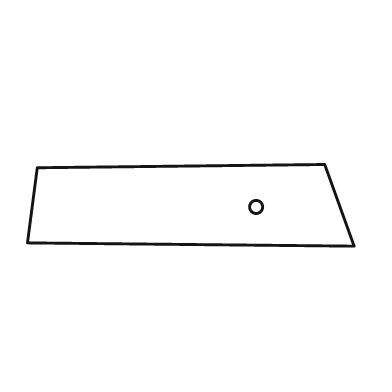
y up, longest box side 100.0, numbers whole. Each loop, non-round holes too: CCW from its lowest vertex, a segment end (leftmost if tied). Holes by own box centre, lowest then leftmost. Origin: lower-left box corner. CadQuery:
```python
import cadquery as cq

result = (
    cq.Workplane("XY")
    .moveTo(100.0, 0.0)
    .lineTo(91.0, 25.0)
    .lineTo(3.0, 24.0)
    .lineTo(0.0, 1.0)
    .close()
    .moveTo(70.0, 12.0)
    .circle(2.0)
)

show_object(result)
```